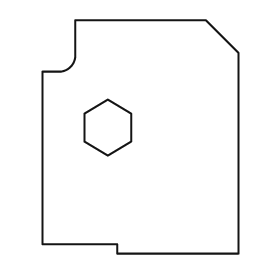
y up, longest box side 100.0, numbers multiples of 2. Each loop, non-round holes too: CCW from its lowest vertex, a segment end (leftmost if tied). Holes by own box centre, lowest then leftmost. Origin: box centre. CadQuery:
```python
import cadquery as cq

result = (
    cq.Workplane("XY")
    .moveTo(-10.0, -50.0)
    .lineTo(42.0, -50.0)
    .lineTo(42.0, 36.0)
    .lineTo(28.0, 50.0)
    .lineTo(-28.0, 50.0)
    .lineTo(-28.0, 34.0)
    .threePointArc((-30.0, 30.0), (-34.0, 28.0))
    .lineTo(-42.0, 28.0)
    .lineTo(-42.0, -46.0)
    .lineTo(-10.0, -46.0)
    .close()
    .moveTo(-14.0, -8.0)
    .lineTo(-4.0, -2.0)
    .lineTo(-4.0, 10.0)
    .lineTo(-14.0, 16.0)
    .lineTo(-24.0, 10.0)
    .lineTo(-24.0, -2.0)
    .close()
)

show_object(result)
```